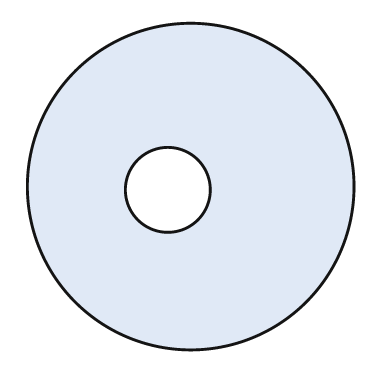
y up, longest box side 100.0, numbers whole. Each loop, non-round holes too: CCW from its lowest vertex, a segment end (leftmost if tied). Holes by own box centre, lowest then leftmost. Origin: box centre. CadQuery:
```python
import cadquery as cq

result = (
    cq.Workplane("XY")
    .moveTo(0.0, 0.0)
    .circle(50.0)
    .moveTo(-7.0, -1.0)
    .circle(13.0)
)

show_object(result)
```